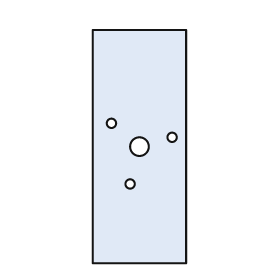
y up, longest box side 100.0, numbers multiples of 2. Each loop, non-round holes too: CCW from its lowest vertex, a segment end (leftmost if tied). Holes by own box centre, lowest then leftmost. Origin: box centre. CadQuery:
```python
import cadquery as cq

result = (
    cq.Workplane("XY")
    .moveTo(-20.0, -50.0)
    .lineTo(20.0, -50.0)
    .lineTo(20.0, 50.0)
    .lineTo(-20.0, 50.0)
    .close()
    .moveTo(-4.0, -16.0)
    .circle(2.0)
    .moveTo(0.0, 0.0)
    .circle(4.0)
    .moveTo(14.0, 4.0)
    .circle(2.0)
    .moveTo(-12.0, 10.0)
    .circle(2.0)
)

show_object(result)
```